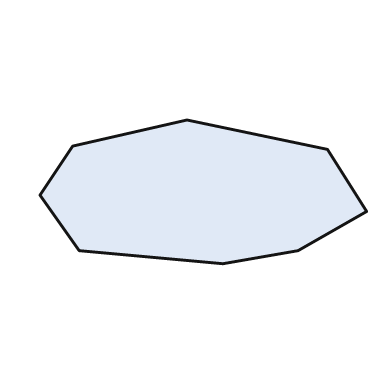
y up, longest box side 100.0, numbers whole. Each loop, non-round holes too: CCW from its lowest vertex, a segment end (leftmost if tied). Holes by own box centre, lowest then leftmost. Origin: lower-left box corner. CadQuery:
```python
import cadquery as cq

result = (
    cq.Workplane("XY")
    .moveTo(56.0, 0.0)
    .lineTo(79.0, 4.0)
    .lineTo(100.0, 16.0)
    .lineTo(88.0, 35.0)
    .lineTo(45.0, 44.0)
    .lineTo(10.0, 36.0)
    .lineTo(0.0, 21.0)
    .lineTo(12.0, 4.0)
    .close()
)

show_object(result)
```